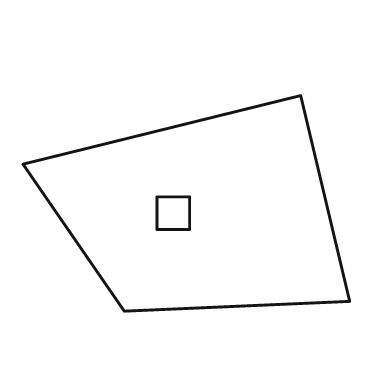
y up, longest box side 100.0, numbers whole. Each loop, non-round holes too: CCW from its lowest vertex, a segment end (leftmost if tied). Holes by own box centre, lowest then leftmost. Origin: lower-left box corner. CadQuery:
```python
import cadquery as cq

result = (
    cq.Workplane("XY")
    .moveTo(31.0, 0.0)
    .lineTo(100.0, 3.0)
    .lineTo(85.0, 66.0)
    .lineTo(0.0, 45.0)
    .close()
    .moveTo(41.0, 25.0)
    .lineTo(51.0, 25.0)
    .lineTo(51.0, 35.0)
    .lineTo(41.0, 35.0)
    .close()
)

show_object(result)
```